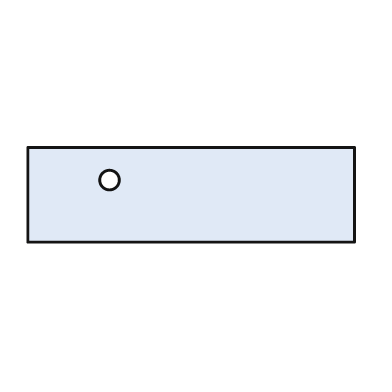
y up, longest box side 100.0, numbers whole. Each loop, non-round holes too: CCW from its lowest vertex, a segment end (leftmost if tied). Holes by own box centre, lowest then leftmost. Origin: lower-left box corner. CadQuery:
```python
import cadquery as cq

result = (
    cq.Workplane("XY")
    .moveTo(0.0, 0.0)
    .lineTo(100.0, 0.0)
    .lineTo(100.0, 29.0)
    .lineTo(0.0, 29.0)
    .close()
    .moveTo(25.0, 19.0)
    .circle(3.0)
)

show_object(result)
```